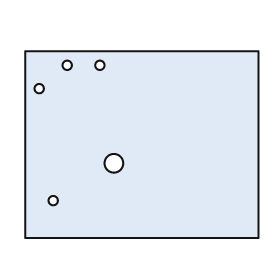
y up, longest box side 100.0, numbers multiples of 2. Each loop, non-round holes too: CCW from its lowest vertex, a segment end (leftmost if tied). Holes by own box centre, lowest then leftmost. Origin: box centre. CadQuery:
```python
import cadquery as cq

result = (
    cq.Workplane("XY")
    .moveTo(-50.0, -40.0)
    .lineTo(50.0, -40.0)
    .lineTo(50.0, 40.0)
    .lineTo(-50.0, 40.0)
    .close()
    .moveTo(-38.0, -24.0)
    .circle(2.0)
    .moveTo(-12.0, -8.0)
    .circle(4.0)
    .moveTo(-44.0, 24.0)
    .circle(2.0)
    .moveTo(-32.0, 34.0)
    .circle(2.0)
    .moveTo(-18.0, 34.0)
    .circle(2.0)
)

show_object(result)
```